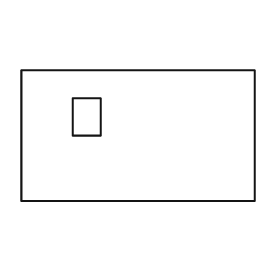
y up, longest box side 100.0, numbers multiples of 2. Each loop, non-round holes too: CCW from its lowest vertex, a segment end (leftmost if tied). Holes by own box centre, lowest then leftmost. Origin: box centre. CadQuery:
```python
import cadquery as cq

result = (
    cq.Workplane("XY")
    .moveTo(-50.0, -28.0)
    .lineTo(50.0, -28.0)
    .lineTo(50.0, 28.0)
    .lineTo(-50.0, 28.0)
    .close()
    .moveTo(-28.0, 0.0)
    .lineTo(-16.0, 0.0)
    .lineTo(-16.0, 16.0)
    .lineTo(-28.0, 16.0)
    .close()
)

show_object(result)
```